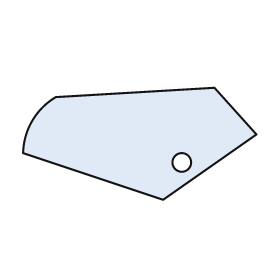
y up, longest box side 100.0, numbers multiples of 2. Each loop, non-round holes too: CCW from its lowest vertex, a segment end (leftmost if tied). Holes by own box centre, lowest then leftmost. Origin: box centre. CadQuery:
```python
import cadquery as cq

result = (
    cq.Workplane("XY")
    .moveTo(10.0, -24.0)
    .lineTo(50.0, 4.0)
    .lineTo(32.0, 24.0)
    .lineTo(-36.0, 20.0)
    .threePointArc((-46.0, 10.0), (-50.0, -4.0))
    .close()
    .moveTo(18.0, -8.0)
    .circle(4.0)
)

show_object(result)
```